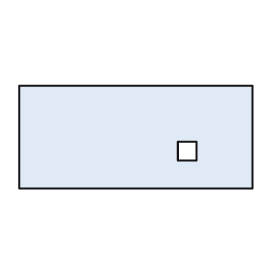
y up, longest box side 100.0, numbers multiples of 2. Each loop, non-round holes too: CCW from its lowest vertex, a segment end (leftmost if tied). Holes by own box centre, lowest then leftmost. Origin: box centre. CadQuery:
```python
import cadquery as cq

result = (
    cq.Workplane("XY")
    .moveTo(-50.0, -22.0)
    .lineTo(50.0, -22.0)
    .lineTo(50.0, 22.0)
    .lineTo(-50.0, 22.0)
    .close()
    .moveTo(18.0, -10.0)
    .lineTo(26.0, -10.0)
    .lineTo(26.0, -2.0)
    .lineTo(18.0, -2.0)
    .close()
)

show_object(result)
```